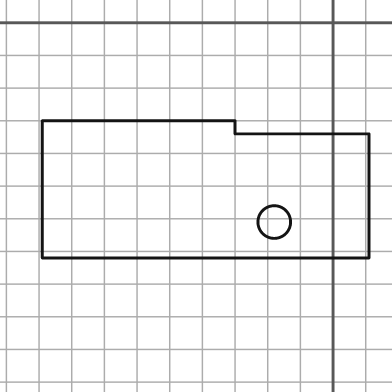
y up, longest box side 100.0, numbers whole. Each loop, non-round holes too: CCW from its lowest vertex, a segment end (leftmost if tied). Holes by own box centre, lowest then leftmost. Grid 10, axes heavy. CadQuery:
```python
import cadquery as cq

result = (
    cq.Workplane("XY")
    .moveTo(-89.0, -72.0)
    .lineTo(11.0, -72.0)
    .lineTo(11.0, -34.0)
    .lineTo(-30.0, -34.0)
    .lineTo(-30.0, -30.0)
    .lineTo(-89.0, -30.0)
    .close()
    .moveTo(-18.0, -61.0)
    .circle(5.0)
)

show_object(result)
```